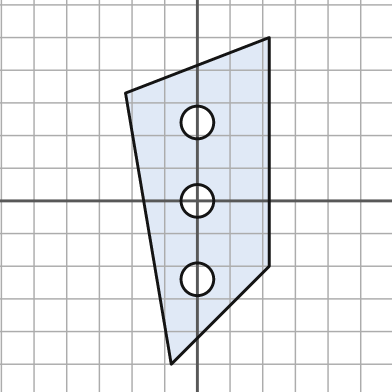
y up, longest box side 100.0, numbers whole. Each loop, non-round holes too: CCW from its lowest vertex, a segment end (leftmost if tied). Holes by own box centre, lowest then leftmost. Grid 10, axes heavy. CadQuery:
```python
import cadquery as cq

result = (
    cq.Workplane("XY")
    .moveTo(-8.0, -50.0)
    .lineTo(22.0, -20.0)
    .lineTo(22.0, 50.0)
    .lineTo(-22.0, 33.0)
    .close()
    .moveTo(0.0, -24.0)
    .circle(5.0)
    .moveTo(0.0, 0.0)
    .circle(5.0)
    .moveTo(0.0, 24.0)
    .circle(5.0)
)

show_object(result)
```